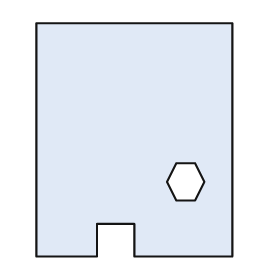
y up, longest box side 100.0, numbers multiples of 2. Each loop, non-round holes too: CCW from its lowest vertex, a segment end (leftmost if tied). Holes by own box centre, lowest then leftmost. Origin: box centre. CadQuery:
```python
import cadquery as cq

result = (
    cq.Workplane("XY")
    .moveTo(-42.0, -50.0)
    .lineTo(-16.0, -50.0)
    .lineTo(-16.0, -36.0)
    .lineTo(0.0, -36.0)
    .lineTo(0.0, -50.0)
    .lineTo(42.0, -50.0)
    .lineTo(42.0, 50.0)
    .lineTo(-42.0, 50.0)
    .close()
    .moveTo(18.0, -26.0)
    .lineTo(26.0, -26.0)
    .lineTo(30.0, -18.0)
    .lineTo(26.0, -10.0)
    .lineTo(18.0, -10.0)
    .lineTo(14.0, -18.0)
    .close()
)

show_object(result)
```